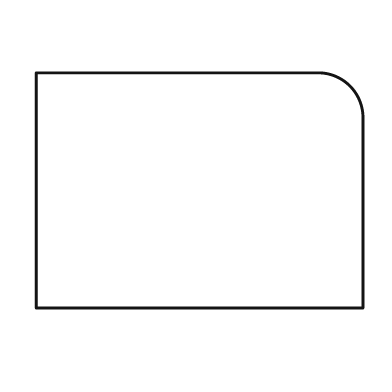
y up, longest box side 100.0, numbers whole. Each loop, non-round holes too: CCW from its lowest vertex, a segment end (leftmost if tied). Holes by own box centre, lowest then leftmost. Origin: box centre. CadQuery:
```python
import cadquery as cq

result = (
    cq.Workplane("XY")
    .moveTo(-50.0, -36.0)
    .lineTo(50.0, -36.0)
    .lineTo(50.0, 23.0)
    .threePointArc((46.0, 32.0), (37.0, 36.0))
    .lineTo(-50.0, 36.0)
    .close()
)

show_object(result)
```